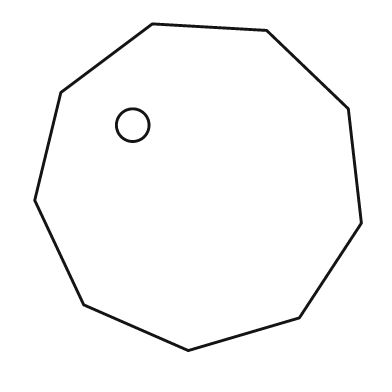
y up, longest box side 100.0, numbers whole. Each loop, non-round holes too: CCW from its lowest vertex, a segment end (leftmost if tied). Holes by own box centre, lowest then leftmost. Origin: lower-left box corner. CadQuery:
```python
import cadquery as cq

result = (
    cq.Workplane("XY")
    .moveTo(47.0, 0.0)
    .lineTo(81.0, 10.0)
    .lineTo(100.0, 39.0)
    .lineTo(96.0, 74.0)
    .lineTo(71.0, 98.0)
    .lineTo(36.0, 100.0)
    .lineTo(8.0, 79.0)
    .lineTo(0.0, 46.0)
    .lineTo(15.0, 14.0)
    .close()
    .moveTo(30.0, 69.0)
    .circle(5.0)
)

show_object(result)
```